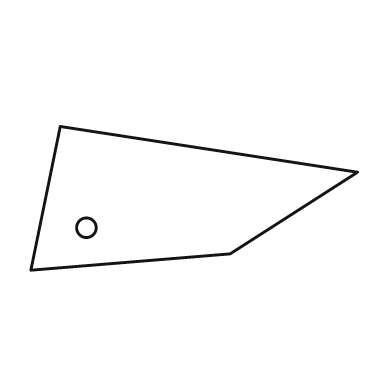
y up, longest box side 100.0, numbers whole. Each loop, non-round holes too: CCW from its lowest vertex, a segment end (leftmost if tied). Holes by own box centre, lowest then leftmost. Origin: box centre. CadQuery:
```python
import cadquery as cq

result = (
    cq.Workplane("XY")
    .moveTo(-50.0, -22.0)
    .lineTo(11.0, -17.0)
    .lineTo(50.0, 8.0)
    .lineTo(-41.0, 22.0)
    .close()
    .moveTo(-33.0, -9.0)
    .circle(3.0)
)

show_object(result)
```